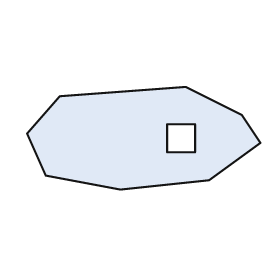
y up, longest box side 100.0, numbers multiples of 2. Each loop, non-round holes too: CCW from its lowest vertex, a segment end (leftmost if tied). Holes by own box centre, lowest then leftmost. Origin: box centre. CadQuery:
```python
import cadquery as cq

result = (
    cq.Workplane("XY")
    .moveTo(-10.0, -22.0)
    .lineTo(28.0, -18.0)
    .lineTo(50.0, -2.0)
    .lineTo(42.0, 10.0)
    .lineTo(18.0, 22.0)
    .lineTo(-36.0, 18.0)
    .lineTo(-50.0, 2.0)
    .lineTo(-42.0, -16.0)
    .close()
    .moveTo(10.0, -6.0)
    .lineTo(22.0, -6.0)
    .lineTo(22.0, 6.0)
    .lineTo(10.0, 6.0)
    .close()
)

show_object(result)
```